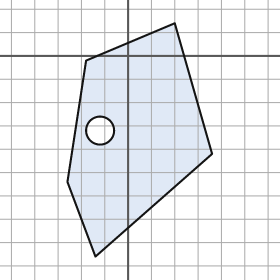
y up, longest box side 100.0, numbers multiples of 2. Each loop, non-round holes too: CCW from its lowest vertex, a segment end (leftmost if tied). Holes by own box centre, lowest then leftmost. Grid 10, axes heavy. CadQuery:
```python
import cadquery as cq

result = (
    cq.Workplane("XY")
    .moveTo(-14.0, -86.0)
    .lineTo(36.0, -42.0)
    .lineTo(20.0, 14.0)
    .lineTo(-18.0, -2.0)
    .lineTo(-26.0, -54.0)
    .close()
    .moveTo(-12.0, -32.0)
    .circle(6.0)
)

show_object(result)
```